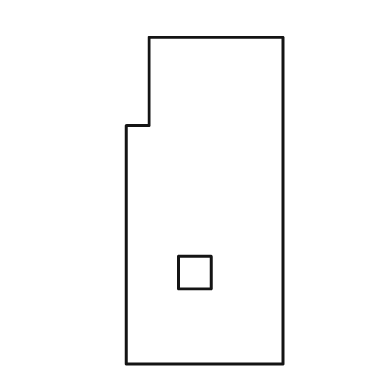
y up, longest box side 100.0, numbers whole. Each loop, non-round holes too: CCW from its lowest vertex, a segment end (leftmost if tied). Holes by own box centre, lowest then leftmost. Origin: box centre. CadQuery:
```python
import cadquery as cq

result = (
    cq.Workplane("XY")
    .moveTo(-24.0, -50.0)
    .lineTo(24.0, -50.0)
    .lineTo(24.0, 50.0)
    .lineTo(-17.0, 50.0)
    .lineTo(-17.0, 23.0)
    .lineTo(-24.0, 23.0)
    .close()
    .moveTo(-8.0, -27.0)
    .lineTo(2.0, -27.0)
    .lineTo(2.0, -17.0)
    .lineTo(-8.0, -17.0)
    .close()
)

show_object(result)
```